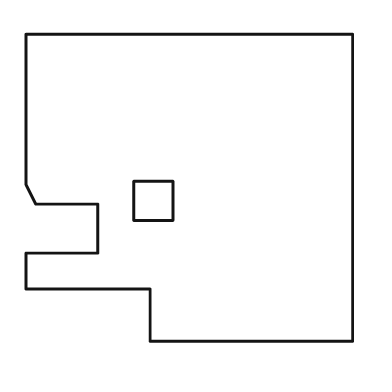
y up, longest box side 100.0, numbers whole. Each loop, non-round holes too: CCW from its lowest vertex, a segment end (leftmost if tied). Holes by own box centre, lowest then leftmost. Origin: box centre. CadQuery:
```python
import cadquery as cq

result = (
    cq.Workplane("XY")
    .moveTo(-12.0, -47.0)
    .lineTo(50.0, -47.0)
    .lineTo(50.0, 47.0)
    .lineTo(-50.0, 47.0)
    .lineTo(-50.0, 1.0)
    .lineTo(-47.0, -5.0)
    .lineTo(-28.0, -5.0)
    .lineTo(-28.0, -20.0)
    .lineTo(-50.0, -20.0)
    .lineTo(-50.0, -31.0)
    .lineTo(-12.0, -31.0)
    .close()
    .moveTo(-17.0, -10.0)
    .lineTo(-5.0, -10.0)
    .lineTo(-5.0, 2.0)
    .lineTo(-17.0, 2.0)
    .close()
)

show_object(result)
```